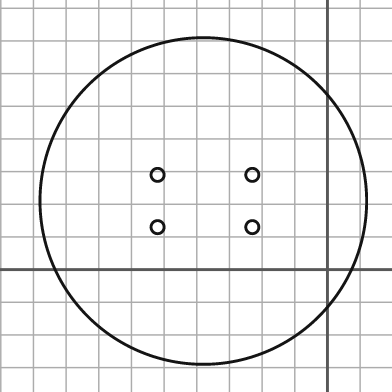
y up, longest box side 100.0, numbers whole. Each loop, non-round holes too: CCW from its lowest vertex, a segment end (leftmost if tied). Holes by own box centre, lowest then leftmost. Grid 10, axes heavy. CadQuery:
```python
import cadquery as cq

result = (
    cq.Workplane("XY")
    .moveTo(-38.0, 21.0)
    .circle(50.0)
    .moveTo(-52.0, 13.0)
    .circle(2.0)
    .moveTo(-23.0, 13.0)
    .circle(2.0)
    .moveTo(-52.0, 29.0)
    .circle(2.0)
    .moveTo(-23.0, 29.0)
    .circle(2.0)
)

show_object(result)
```